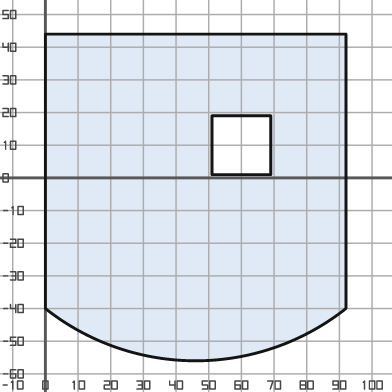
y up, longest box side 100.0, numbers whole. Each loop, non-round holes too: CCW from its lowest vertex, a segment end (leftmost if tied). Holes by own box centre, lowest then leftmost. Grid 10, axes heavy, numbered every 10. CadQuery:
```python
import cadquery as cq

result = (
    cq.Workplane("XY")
    .moveTo(0.0, -40.0)
    .threePointArc((46.0, -56.0), (92.0, -40.0))
    .lineTo(92.0, 44.0)
    .lineTo(0.0, 44.0)
    .close()
    .moveTo(51.0, 1.0)
    .lineTo(69.0, 1.0)
    .lineTo(69.0, 19.0)
    .lineTo(51.0, 19.0)
    .close()
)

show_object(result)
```